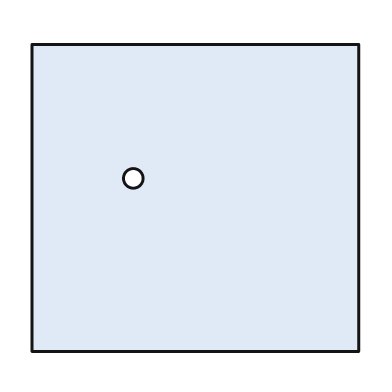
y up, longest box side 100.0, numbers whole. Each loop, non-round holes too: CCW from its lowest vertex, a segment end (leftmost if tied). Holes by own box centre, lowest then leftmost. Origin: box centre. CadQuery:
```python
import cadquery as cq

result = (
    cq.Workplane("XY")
    .moveTo(-50.0, -47.0)
    .lineTo(50.0, -47.0)
    .lineTo(50.0, 47.0)
    .lineTo(-50.0, 47.0)
    .close()
    .moveTo(-19.0, 6.0)
    .circle(3.0)
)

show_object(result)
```